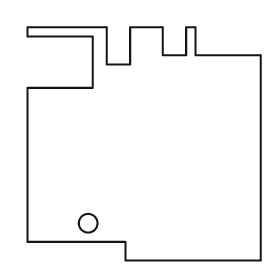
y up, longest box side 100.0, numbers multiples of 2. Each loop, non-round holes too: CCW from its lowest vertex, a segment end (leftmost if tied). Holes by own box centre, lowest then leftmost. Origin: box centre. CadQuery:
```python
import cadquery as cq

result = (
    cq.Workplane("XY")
    .moveTo(-8.0, -50.0)
    .lineTo(50.0, -50.0)
    .lineTo(50.0, 38.0)
    .lineTo(22.0, 38.0)
    .lineTo(22.0, 50.0)
    .lineTo(18.0, 50.0)
    .lineTo(18.0, 38.0)
    .lineTo(8.0, 38.0)
    .lineTo(8.0, 50.0)
    .lineTo(-6.0, 50.0)
    .lineTo(-6.0, 34.0)
    .lineTo(-16.0, 34.0)
    .lineTo(-16.0, 50.0)
    .lineTo(-50.0, 50.0)
    .lineTo(-50.0, 46.0)
    .lineTo(-22.0, 46.0)
    .lineTo(-22.0, 24.0)
    .lineTo(-50.0, 24.0)
    .lineTo(-50.0, -42.0)
    .lineTo(-8.0, -42.0)
    .close()
    .moveTo(-24.0, -34.0)
    .circle(4.0)
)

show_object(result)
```